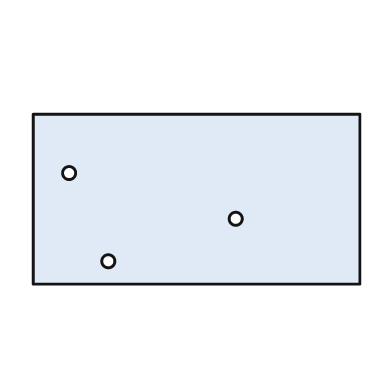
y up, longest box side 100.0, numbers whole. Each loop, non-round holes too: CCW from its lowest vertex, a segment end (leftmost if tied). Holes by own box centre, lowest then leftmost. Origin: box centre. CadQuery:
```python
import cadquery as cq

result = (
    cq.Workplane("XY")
    .moveTo(-50.0, -26.0)
    .lineTo(50.0, -26.0)
    .lineTo(50.0, 26.0)
    .lineTo(-50.0, 26.0)
    .close()
    .moveTo(-27.0, -19.0)
    .circle(2.0)
    .moveTo(12.0, -6.0)
    .circle(2.0)
    .moveTo(-39.0, 8.0)
    .circle(2.0)
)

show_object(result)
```